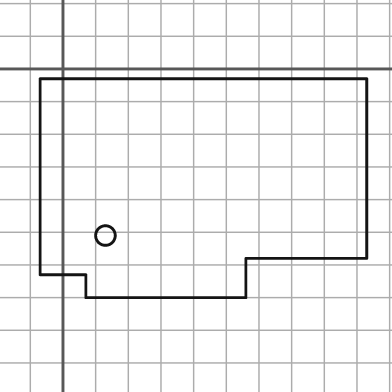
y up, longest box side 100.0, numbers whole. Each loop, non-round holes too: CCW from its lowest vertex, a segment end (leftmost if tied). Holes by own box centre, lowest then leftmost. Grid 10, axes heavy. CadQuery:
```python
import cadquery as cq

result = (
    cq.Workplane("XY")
    .moveTo(7.0, -70.0)
    .lineTo(56.0, -70.0)
    .lineTo(56.0, -58.0)
    .lineTo(93.0, -58.0)
    .lineTo(93.0, -3.0)
    .lineTo(-7.0, -3.0)
    .lineTo(-7.0, -63.0)
    .lineTo(7.0, -63.0)
    .close()
    .moveTo(13.0, -51.0)
    .circle(3.0)
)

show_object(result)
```